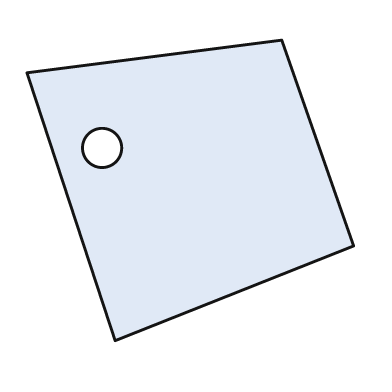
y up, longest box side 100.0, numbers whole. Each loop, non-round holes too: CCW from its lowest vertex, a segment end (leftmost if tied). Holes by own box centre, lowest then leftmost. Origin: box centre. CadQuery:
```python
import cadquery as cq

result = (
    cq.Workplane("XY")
    .moveTo(-23.0, -46.0)
    .lineTo(50.0, -17.0)
    .lineTo(28.0, 46.0)
    .lineTo(-50.0, 36.0)
    .close()
    .moveTo(-27.0, 13.0)
    .circle(6.0)
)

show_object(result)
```